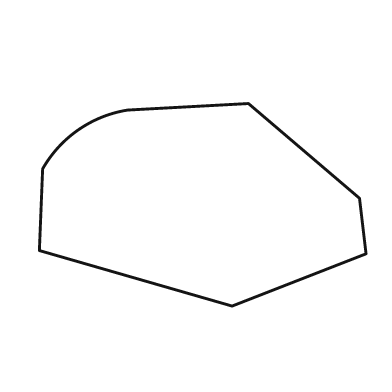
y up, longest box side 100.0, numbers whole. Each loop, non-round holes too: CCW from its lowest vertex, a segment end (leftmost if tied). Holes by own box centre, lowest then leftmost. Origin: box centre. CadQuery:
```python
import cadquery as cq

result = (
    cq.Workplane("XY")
    .moveTo(9.0, -31.0)
    .lineTo(50.0, -15.0)
    .lineTo(48.0, 2.0)
    .lineTo(14.0, 31.0)
    .lineTo(-23.0, 29.0)
    .threePointArc((-38.0, 23.0), (-49.0, 11.0))
    .lineTo(-50.0, -14.0)
    .close()
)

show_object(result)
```